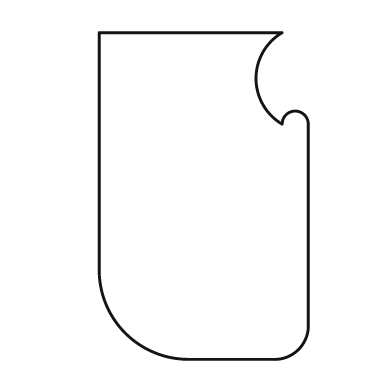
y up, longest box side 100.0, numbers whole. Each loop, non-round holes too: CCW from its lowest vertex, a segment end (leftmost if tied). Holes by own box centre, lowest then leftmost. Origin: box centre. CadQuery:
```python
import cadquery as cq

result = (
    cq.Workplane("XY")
    .moveTo(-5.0, -50.0)
    .lineTo(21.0, -50.0)
    .threePointArc((29.0, -47.0), (32.0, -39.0))
    .lineTo(32.0, 22.0)
    .threePointArc((28.0, 26.0), (24.0, 22.0))
    .threePointArc((16.0, 36.0), (24.0, 50.0))
    .lineTo(-32.0, 50.0)
    .lineTo(-32.0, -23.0)
    .threePointArc((-24.0, -42.0), (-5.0, -50.0))
    .close()
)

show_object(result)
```